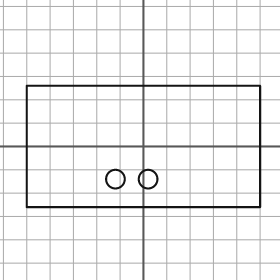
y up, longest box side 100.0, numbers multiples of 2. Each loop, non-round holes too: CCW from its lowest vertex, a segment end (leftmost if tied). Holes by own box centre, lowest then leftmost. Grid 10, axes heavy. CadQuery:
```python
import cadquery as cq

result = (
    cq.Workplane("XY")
    .moveTo(-50.0, -26.0)
    .lineTo(50.0, -26.0)
    .lineTo(50.0, 26.0)
    .lineTo(-50.0, 26.0)
    .close()
    .moveTo(-12.0, -14.0)
    .circle(4.0)
    .moveTo(2.0, -14.0)
    .circle(4.0)
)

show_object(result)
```